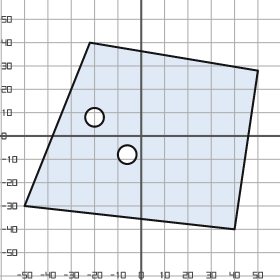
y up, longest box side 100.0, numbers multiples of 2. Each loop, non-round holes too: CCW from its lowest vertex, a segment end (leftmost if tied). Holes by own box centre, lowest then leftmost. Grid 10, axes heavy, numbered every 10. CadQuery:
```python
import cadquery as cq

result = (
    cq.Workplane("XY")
    .moveTo(40.0, -40.0)
    .lineTo(50.0, 28.0)
    .lineTo(-22.0, 40.0)
    .lineTo(-50.0, -30.0)
    .close()
    .moveTo(-6.0, -8.0)
    .circle(4.0)
    .moveTo(-20.0, 8.0)
    .circle(4.0)
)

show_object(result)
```